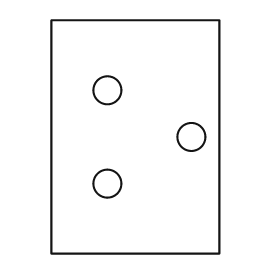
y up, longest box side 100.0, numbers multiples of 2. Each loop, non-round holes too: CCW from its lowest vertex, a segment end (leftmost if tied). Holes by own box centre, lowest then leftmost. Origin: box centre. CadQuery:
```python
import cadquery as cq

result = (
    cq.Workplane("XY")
    .moveTo(-36.0, -50.0)
    .lineTo(36.0, -50.0)
    .lineTo(36.0, 50.0)
    .lineTo(-36.0, 50.0)
    .close()
    .moveTo(-12.0, -20.0)
    .circle(6.0)
    .moveTo(24.0, 0.0)
    .circle(6.0)
    .moveTo(-12.0, 20.0)
    .circle(6.0)
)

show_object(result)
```